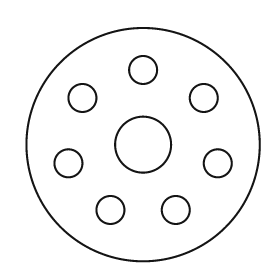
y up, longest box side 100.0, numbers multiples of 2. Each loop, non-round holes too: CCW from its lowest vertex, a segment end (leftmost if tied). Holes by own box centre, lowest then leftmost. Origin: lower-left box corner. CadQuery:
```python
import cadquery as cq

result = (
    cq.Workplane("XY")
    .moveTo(50.0, 50.0)
    .circle(50.0)
    .moveTo(36.0, 22.0)
    .circle(6.0)
    .moveTo(64.0, 22.0)
    .circle(6.0)
    .moveTo(18.0, 42.0)
    .circle(6.0)
    .moveTo(82.0, 42.0)
    .circle(6.0)
    .moveTo(50.0, 50.0)
    .circle(12.0)
    .moveTo(24.0, 70.0)
    .circle(6.0)
    .moveTo(76.0, 70.0)
    .circle(6.0)
    .moveTo(50.0, 82.0)
    .circle(6.0)
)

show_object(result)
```